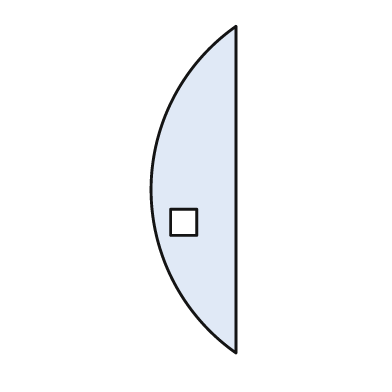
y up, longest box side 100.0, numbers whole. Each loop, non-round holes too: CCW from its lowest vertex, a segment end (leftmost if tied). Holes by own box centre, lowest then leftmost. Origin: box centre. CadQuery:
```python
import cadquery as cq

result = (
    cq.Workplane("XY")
    .moveTo(13.0, -50.0)
    .lineTo(13.0, 50.0)
    .threePointArc((-13.0, 0.0), (13.0, -50.0))
    .close()
    .moveTo(-7.0, -14.0)
    .lineTo(1.0, -14.0)
    .lineTo(1.0, -6.0)
    .lineTo(-7.0, -6.0)
    .close()
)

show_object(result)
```